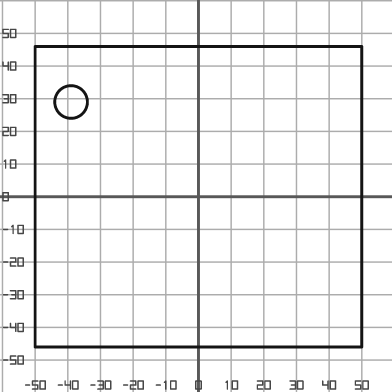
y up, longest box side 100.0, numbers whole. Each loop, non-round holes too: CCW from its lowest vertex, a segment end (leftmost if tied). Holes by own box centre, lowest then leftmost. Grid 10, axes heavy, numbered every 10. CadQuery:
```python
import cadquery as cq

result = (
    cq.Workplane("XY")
    .moveTo(-50.0, -46.0)
    .lineTo(50.0, -46.0)
    .lineTo(50.0, 46.0)
    .lineTo(-50.0, 46.0)
    .close()
    .moveTo(-39.0, 29.0)
    .circle(5.0)
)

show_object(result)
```